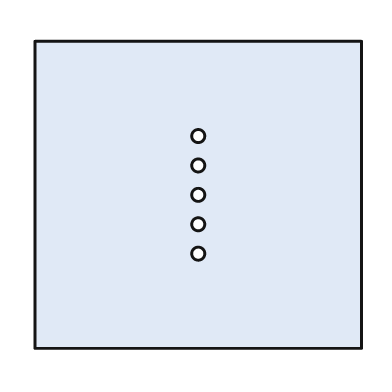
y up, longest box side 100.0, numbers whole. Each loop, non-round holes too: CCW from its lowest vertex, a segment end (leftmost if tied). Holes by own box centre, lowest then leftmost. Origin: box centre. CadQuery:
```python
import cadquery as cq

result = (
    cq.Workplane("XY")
    .moveTo(-50.0, -47.0)
    .lineTo(50.0, -47.0)
    .lineTo(50.0, 47.0)
    .lineTo(-50.0, 47.0)
    .close()
    .moveTo(0.0, -18.0)
    .circle(2.0)
    .moveTo(0.0, -9.0)
    .circle(2.0)
    .moveTo(0.0, 0.0)
    .circle(2.0)
    .moveTo(0.0, 9.0)
    .circle(2.0)
    .moveTo(0.0, 18.0)
    .circle(2.0)
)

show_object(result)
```